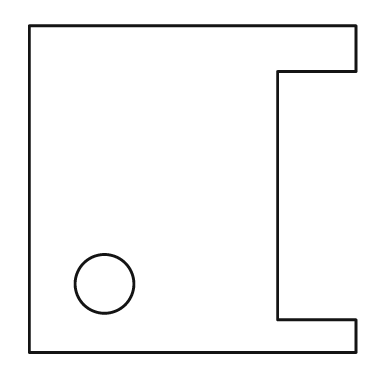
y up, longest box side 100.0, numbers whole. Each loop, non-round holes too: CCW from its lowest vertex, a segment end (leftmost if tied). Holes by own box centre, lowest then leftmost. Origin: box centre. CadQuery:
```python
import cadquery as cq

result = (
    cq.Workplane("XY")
    .moveTo(-50.0, -50.0)
    .lineTo(50.0, -50.0)
    .lineTo(50.0, -40.0)
    .lineTo(26.0, -40.0)
    .lineTo(26.0, 36.0)
    .lineTo(50.0, 36.0)
    .lineTo(50.0, 50.0)
    .lineTo(-50.0, 50.0)
    .close()
    .moveTo(-27.0, -29.0)
    .circle(9.0)
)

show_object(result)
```